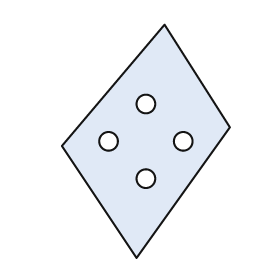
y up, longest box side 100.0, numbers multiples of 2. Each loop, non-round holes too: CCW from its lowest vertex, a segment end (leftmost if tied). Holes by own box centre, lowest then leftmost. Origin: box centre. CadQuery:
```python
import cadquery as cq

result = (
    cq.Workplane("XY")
    .moveTo(-4.0, -50.0)
    .lineTo(36.0, 6.0)
    .lineTo(8.0, 50.0)
    .lineTo(-36.0, -2.0)
    .close()
    .moveTo(0.0, -16.0)
    .circle(4.0)
    .moveTo(-16.0, 0.0)
    .circle(4.0)
    .moveTo(16.0, 0.0)
    .circle(4.0)
    .moveTo(0.0, 16.0)
    .circle(4.0)
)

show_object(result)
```